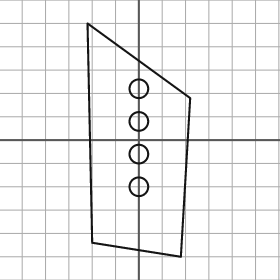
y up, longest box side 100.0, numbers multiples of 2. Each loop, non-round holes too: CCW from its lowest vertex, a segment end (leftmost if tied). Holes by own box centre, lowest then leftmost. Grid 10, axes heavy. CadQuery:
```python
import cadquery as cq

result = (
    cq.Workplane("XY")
    .moveTo(18.0, -50.0)
    .lineTo(22.0, 18.0)
    .lineTo(-22.0, 50.0)
    .lineTo(-20.0, -44.0)
    .close()
    .moveTo(0.0, -20.0)
    .circle(4.0)
    .moveTo(0.0, -6.0)
    .circle(4.0)
    .moveTo(0.0, 8.0)
    .circle(4.0)
    .moveTo(0.0, 22.0)
    .circle(4.0)
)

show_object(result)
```